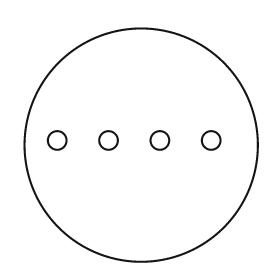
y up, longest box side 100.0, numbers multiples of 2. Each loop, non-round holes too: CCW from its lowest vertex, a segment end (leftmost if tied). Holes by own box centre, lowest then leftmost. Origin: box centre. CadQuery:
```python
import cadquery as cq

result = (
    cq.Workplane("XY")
    .moveTo(0.0, 0.0)
    .circle(50.0)
    .moveTo(-36.0, 2.0)
    .circle(4.0)
    .moveTo(-14.0, 2.0)
    .circle(4.0)
    .moveTo(8.0, 2.0)
    .circle(4.0)
    .moveTo(30.0, 2.0)
    .circle(4.0)
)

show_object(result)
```